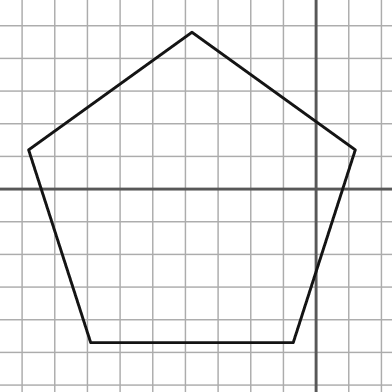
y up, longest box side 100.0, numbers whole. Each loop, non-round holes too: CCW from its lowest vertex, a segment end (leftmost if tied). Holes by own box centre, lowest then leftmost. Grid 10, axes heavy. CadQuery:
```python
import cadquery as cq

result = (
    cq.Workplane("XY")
    .moveTo(-69.0, -47.0)
    .lineTo(-7.0, -47.0)
    .lineTo(12.0, 12.0)
    .lineTo(-38.0, 48.0)
    .lineTo(-88.0, 12.0)
    .close()
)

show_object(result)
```